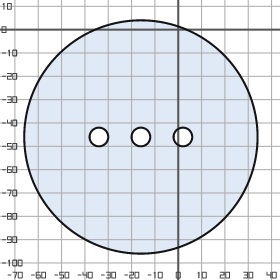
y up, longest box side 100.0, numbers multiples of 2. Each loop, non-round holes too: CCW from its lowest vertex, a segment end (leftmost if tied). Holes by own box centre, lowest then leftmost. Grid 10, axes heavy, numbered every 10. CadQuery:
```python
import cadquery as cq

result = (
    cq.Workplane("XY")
    .moveTo(-16.0, -46.0)
    .circle(50.0)
    .moveTo(-34.0, -46.0)
    .circle(4.0)
    .moveTo(-16.0, -46.0)
    .circle(4.0)
    .moveTo(2.0, -46.0)
    .circle(4.0)
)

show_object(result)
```